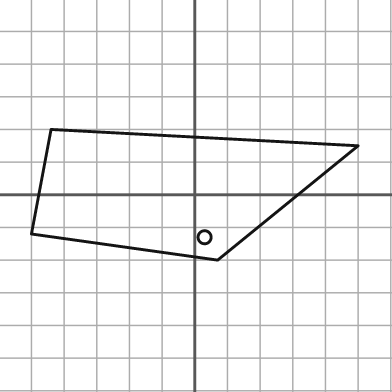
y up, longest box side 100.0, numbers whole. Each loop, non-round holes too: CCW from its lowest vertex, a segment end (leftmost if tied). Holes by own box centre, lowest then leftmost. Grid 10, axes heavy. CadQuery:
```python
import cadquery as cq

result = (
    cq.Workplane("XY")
    .moveTo(7.0, -20.0)
    .lineTo(50.0, 15.0)
    .lineTo(-44.0, 20.0)
    .lineTo(-50.0, -12.0)
    .close()
    .moveTo(3.0, -13.0)
    .circle(2.0)
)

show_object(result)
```